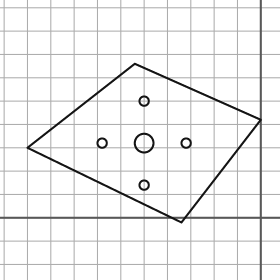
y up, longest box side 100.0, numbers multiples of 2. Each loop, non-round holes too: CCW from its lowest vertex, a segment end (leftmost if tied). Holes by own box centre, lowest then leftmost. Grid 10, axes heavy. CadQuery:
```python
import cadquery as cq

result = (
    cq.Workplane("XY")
    .moveTo(-34.0, -2.0)
    .lineTo(0.0, 42.0)
    .lineTo(-54.0, 66.0)
    .lineTo(-100.0, 30.0)
    .close()
    .moveTo(-50.0, 14.0)
    .circle(2.0)
    .moveTo(-68.0, 32.0)
    .circle(2.0)
    .moveTo(-50.0, 32.0)
    .circle(4.0)
    .moveTo(-32.0, 32.0)
    .circle(2.0)
    .moveTo(-50.0, 50.0)
    .circle(2.0)
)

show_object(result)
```